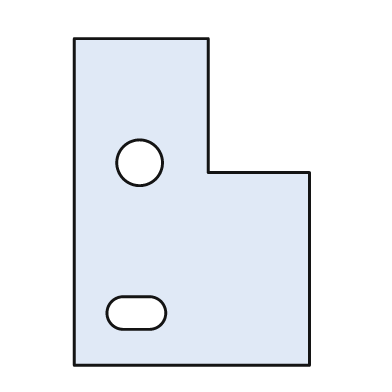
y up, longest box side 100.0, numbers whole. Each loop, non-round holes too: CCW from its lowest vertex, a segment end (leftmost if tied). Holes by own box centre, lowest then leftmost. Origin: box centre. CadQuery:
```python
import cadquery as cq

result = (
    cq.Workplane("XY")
    .moveTo(-36.0, -50.0)
    .lineTo(36.0, -50.0)
    .lineTo(36.0, 9.0)
    .lineTo(5.0, 9.0)
    .lineTo(5.0, 50.0)
    .lineTo(-36.0, 50.0)
    .close()
    .moveTo(-21.0, -39.0)
    .lineTo(-13.0, -39.0)
    .threePointArc((-8.0, -34.0), (-13.0, -29.0))
    .lineTo(-21.0, -29.0)
    .threePointArc((-26.0, -34.0), (-21.0, -39.0))
    .close()
    .moveTo(-16.0, 12.0)
    .circle(7.0)
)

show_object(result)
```